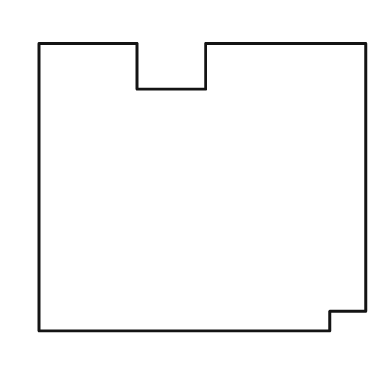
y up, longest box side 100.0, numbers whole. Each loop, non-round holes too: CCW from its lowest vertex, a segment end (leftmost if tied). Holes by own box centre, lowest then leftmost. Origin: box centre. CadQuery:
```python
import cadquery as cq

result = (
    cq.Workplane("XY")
    .moveTo(-50.0, -44.0)
    .lineTo(39.0, -44.0)
    .lineTo(39.0, -38.0)
    .lineTo(50.0, -38.0)
    .lineTo(50.0, 44.0)
    .lineTo(1.0, 44.0)
    .lineTo(1.0, 30.0)
    .lineTo(-20.0, 30.0)
    .lineTo(-20.0, 44.0)
    .lineTo(-50.0, 44.0)
    .close()
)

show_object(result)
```